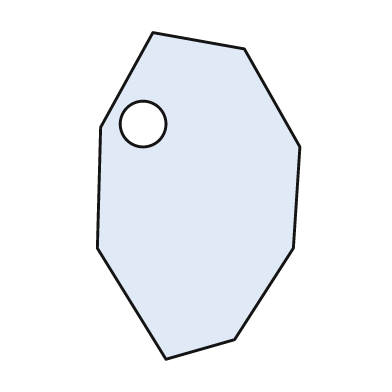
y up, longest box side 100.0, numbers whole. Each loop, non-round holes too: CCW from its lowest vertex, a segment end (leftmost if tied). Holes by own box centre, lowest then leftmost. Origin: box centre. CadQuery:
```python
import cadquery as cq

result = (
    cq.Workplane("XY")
    .moveTo(-10.0, -50.0)
    .lineTo(11.0, -44.0)
    .lineTo(29.0, -16.0)
    .lineTo(31.0, 15.0)
    .lineTo(14.0, 45.0)
    .lineTo(-14.0, 50.0)
    .lineTo(-30.0, 21.0)
    .lineTo(-31.0, -16.0)
    .close()
    .moveTo(-17.0, 22.0)
    .circle(7.0)
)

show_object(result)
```